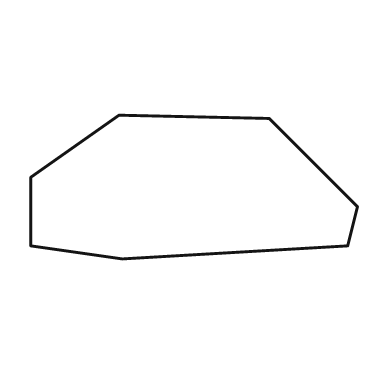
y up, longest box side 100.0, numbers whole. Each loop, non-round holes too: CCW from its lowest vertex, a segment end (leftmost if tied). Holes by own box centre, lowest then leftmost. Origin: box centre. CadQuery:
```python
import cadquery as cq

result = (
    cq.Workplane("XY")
    .moveTo(-22.0, -22.0)
    .lineTo(47.0, -18.0)
    .lineTo(50.0, -6.0)
    .lineTo(23.0, 21.0)
    .lineTo(-23.0, 22.0)
    .lineTo(-50.0, 3.0)
    .lineTo(-50.0, -18.0)
    .close()
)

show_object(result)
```